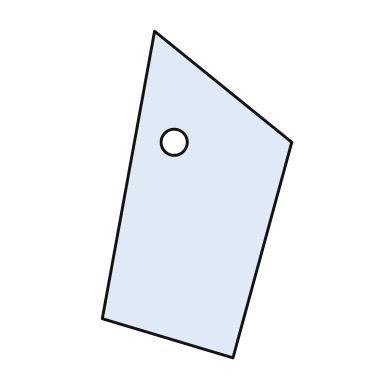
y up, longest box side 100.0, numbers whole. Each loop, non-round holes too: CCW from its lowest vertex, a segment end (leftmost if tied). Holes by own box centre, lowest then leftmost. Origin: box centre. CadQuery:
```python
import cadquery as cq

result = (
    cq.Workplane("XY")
    .moveTo(11.0, -50.0)
    .lineTo(29.0, 16.0)
    .lineTo(-13.0, 50.0)
    .lineTo(-29.0, -38.0)
    .close()
    .moveTo(-7.0, 16.0)
    .circle(4.0)
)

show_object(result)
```